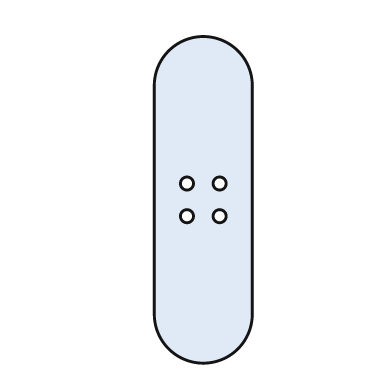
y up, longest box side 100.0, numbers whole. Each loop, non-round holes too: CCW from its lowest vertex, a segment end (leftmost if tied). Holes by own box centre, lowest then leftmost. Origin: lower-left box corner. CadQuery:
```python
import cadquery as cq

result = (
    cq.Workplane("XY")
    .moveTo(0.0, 15.0)
    .threePointArc((15.0, 0.0), (30.0, 15.0))
    .lineTo(30.0, 85.0)
    .threePointArc((15.0, 100.0), (0.0, 85.0))
    .close()
    .moveTo(10.0, 45.0)
    .circle(2.0)
    .moveTo(20.0, 45.0)
    .circle(2.0)
    .moveTo(10.0, 55.0)
    .circle(2.0)
    .moveTo(20.0, 55.0)
    .circle(2.0)
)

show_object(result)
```